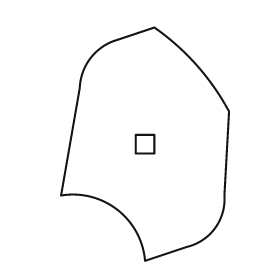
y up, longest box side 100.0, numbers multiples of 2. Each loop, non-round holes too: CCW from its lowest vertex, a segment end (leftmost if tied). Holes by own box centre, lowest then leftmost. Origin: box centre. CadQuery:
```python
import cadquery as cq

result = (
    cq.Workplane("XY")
    .moveTo(0.0, -50.0)
    .lineTo(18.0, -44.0)
    .threePointArc((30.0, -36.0), (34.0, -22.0))
    .lineTo(36.0, 14.0)
    .threePointArc((22.0, 34.0), (4.0, 50.0))
    .lineTo(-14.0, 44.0)
    .threePointArc((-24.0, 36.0), (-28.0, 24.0))
    .lineTo(-36.0, -22.0)
    .threePointArc((-12.0, -28.0), (0.0, -50.0))
    .close()
    .moveTo(-4.0, -4.0)
    .lineTo(4.0, -4.0)
    .lineTo(4.0, 4.0)
    .lineTo(-4.0, 4.0)
    .close()
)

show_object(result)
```